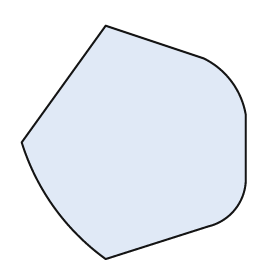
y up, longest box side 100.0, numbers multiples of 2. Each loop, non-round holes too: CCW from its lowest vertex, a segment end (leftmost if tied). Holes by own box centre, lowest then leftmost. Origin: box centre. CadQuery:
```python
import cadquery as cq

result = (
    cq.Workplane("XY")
    .moveTo(-12.0, -50.0)
    .lineTo(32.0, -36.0)
    .threePointArc((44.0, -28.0), (48.0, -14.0))
    .lineTo(48.0, 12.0)
    .threePointArc((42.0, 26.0), (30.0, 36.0))
    .lineTo(-12.0, 50.0)
    .lineTo(-48.0, 0.0)
    .threePointArc((-34.0, -28.0), (-12.0, -50.0))
    .close()
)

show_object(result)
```